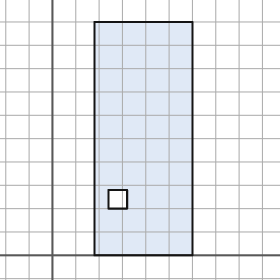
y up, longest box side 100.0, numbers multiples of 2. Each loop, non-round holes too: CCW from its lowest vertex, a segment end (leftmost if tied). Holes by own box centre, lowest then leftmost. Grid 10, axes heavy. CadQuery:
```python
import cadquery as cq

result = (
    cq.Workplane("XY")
    .moveTo(18.0, 0.0)
    .lineTo(60.0, 0.0)
    .lineTo(60.0, 100.0)
    .lineTo(18.0, 100.0)
    .close()
    .moveTo(24.0, 20.0)
    .lineTo(32.0, 20.0)
    .lineTo(32.0, 28.0)
    .lineTo(24.0, 28.0)
    .close()
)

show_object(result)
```